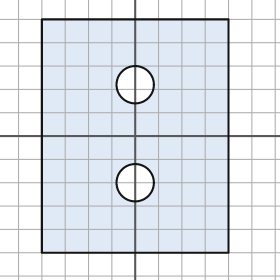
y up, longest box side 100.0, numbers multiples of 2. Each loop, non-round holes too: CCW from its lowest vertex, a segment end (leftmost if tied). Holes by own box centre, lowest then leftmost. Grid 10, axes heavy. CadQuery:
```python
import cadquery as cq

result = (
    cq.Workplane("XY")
    .moveTo(-40.0, -50.0)
    .lineTo(40.0, -50.0)
    .lineTo(40.0, 50.0)
    .lineTo(-40.0, 50.0)
    .close()
    .moveTo(0.0, -20.0)
    .circle(8.0)
    .moveTo(0.0, 22.0)
    .circle(8.0)
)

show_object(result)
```